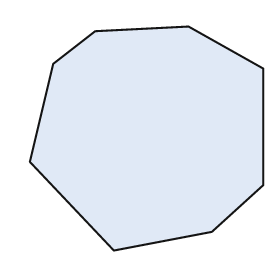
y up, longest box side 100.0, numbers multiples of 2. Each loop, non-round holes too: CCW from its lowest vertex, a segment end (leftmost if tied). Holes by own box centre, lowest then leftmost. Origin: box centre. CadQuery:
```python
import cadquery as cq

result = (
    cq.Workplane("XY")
    .moveTo(-14.0, -48.0)
    .lineTo(28.0, -40.0)
    .lineTo(50.0, -20.0)
    .lineTo(50.0, 30.0)
    .lineTo(18.0, 48.0)
    .lineTo(-22.0, 46.0)
    .lineTo(-40.0, 32.0)
    .lineTo(-50.0, -10.0)
    .close()
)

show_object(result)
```